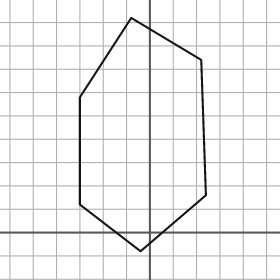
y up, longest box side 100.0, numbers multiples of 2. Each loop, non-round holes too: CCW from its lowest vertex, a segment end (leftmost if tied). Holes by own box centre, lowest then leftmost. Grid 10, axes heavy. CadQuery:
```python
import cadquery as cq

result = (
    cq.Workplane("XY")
    .moveTo(-4.0, -8.0)
    .lineTo(24.0, 16.0)
    .lineTo(22.0, 74.0)
    .lineTo(-8.0, 92.0)
    .lineTo(-30.0, 58.0)
    .lineTo(-30.0, 12.0)
    .close()
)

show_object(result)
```